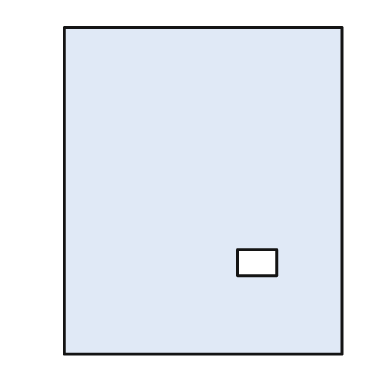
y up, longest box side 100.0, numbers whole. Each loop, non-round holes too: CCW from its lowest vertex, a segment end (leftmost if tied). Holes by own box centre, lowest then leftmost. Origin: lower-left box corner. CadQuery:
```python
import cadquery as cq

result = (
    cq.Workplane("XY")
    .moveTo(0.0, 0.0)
    .lineTo(85.0, 0.0)
    .lineTo(85.0, 100.0)
    .lineTo(0.0, 100.0)
    .close()
    .moveTo(53.0, 24.0)
    .lineTo(65.0, 24.0)
    .lineTo(65.0, 32.0)
    .lineTo(53.0, 32.0)
    .close()
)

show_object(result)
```